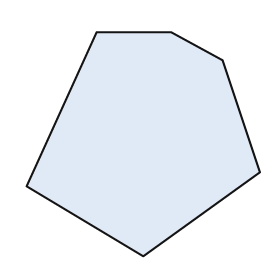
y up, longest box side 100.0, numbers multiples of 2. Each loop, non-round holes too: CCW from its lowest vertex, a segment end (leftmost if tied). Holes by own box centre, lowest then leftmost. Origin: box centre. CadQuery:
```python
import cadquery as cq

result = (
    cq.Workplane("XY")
    .moveTo(0.0, -48.0)
    .lineTo(50.0, -12.0)
    .lineTo(34.0, 36.0)
    .lineTo(12.0, 48.0)
    .lineTo(-20.0, 48.0)
    .lineTo(-50.0, -18.0)
    .close()
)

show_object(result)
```